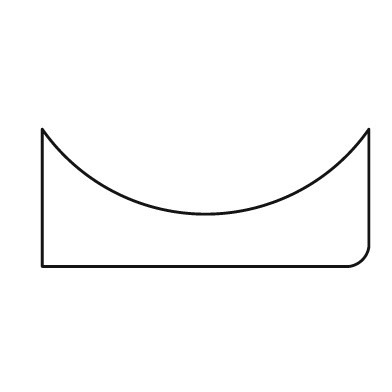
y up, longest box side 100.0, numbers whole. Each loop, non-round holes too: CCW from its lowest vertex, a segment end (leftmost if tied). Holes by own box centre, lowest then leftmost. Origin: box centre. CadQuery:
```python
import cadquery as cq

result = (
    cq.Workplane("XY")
    .moveTo(-50.0, -21.0)
    .lineTo(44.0, -21.0)
    .threePointArc((48.0, -19.0), (50.0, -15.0))
    .lineTo(50.0, 21.0)
    .threePointArc((0.0, -5.0), (-50.0, 21.0))
    .close()
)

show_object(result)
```